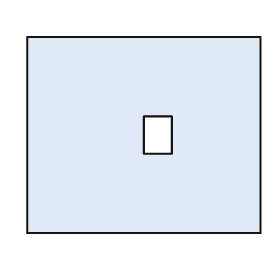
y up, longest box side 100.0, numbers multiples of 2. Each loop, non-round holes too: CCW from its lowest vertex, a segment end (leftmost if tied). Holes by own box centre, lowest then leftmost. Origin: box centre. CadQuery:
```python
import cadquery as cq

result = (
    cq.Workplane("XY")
    .moveTo(-50.0, -42.0)
    .lineTo(50.0, -42.0)
    .lineTo(50.0, 42.0)
    .lineTo(-50.0, 42.0)
    .close()
    .moveTo(0.0, -8.0)
    .lineTo(12.0, -8.0)
    .lineTo(12.0, 8.0)
    .lineTo(0.0, 8.0)
    .close()
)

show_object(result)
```